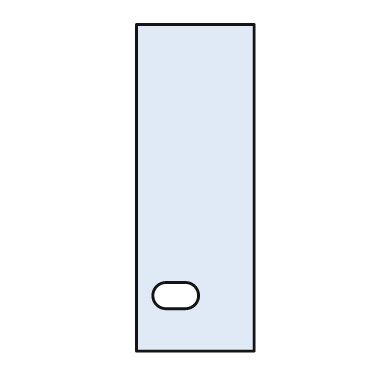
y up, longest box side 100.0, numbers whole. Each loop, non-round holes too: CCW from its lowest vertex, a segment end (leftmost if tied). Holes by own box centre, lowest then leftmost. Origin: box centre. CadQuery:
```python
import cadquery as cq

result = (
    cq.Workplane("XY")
    .moveTo(-18.0, -50.0)
    .lineTo(18.0, -50.0)
    .lineTo(18.0, 50.0)
    .lineTo(-18.0, 50.0)
    .close()
    .moveTo(-9.0, -37.0)
    .lineTo(-3.0, -37.0)
    .threePointArc((1.0, -33.0), (-3.0, -29.0))
    .lineTo(-9.0, -29.0)
    .threePointArc((-13.0, -33.0), (-9.0, -37.0))
    .close()
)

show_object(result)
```